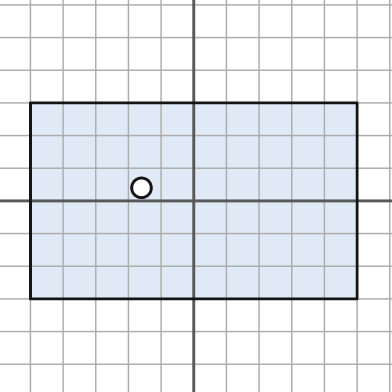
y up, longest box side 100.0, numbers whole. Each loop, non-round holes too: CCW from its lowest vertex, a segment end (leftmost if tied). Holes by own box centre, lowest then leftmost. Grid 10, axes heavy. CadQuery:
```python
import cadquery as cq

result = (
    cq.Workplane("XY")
    .moveTo(-50.0, -30.0)
    .lineTo(50.0, -30.0)
    .lineTo(50.0, 30.0)
    .lineTo(-50.0, 30.0)
    .close()
    .moveTo(-16.0, 4.0)
    .circle(3.0)
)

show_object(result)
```